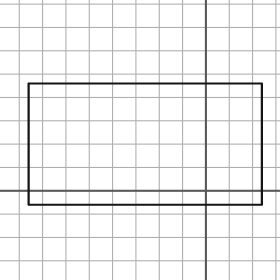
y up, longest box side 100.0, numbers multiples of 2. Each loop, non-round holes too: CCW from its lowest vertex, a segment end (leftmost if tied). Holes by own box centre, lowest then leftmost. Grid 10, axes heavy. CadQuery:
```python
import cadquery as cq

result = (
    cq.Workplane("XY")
    .moveTo(-76.0, -6.0)
    .lineTo(24.0, -6.0)
    .lineTo(24.0, 46.0)
    .lineTo(-76.0, 46.0)
    .close()
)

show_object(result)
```